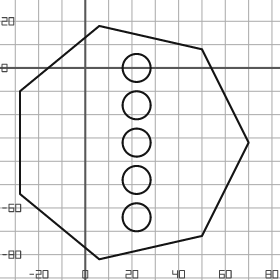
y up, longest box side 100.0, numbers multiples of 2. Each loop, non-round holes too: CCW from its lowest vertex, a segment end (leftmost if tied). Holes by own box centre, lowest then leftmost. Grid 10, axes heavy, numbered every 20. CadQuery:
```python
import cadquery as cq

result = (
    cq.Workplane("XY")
    .moveTo(6.0, -82.0)
    .lineTo(50.0, -72.0)
    .lineTo(70.0, -32.0)
    .lineTo(50.0, 8.0)
    .lineTo(6.0, 18.0)
    .lineTo(-28.0, -10.0)
    .lineTo(-28.0, -54.0)
    .close()
    .moveTo(22.0, -64.0)
    .circle(6.0)
    .moveTo(22.0, -48.0)
    .circle(6.0)
    .moveTo(22.0, -32.0)
    .circle(6.0)
    .moveTo(22.0, -16.0)
    .circle(6.0)
    .moveTo(22.0, 0.0)
    .circle(6.0)
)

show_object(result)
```